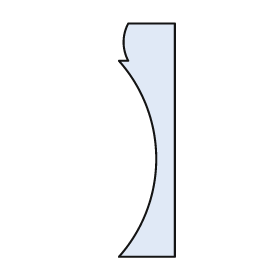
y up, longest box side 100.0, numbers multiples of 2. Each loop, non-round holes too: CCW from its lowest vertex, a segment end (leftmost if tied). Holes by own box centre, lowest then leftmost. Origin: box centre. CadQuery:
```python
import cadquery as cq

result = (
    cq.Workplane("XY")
    .moveTo(-12.0, -50.0)
    .lineTo(12.0, -50.0)
    .lineTo(12.0, 50.0)
    .lineTo(-8.0, 50.0)
    .threePointArc((-10.0, 42.0), (-8.0, 34.0))
    .lineTo(-12.0, 34.0)
    .threePointArc((4.0, -8.0), (-12.0, -50.0))
    .close()
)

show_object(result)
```